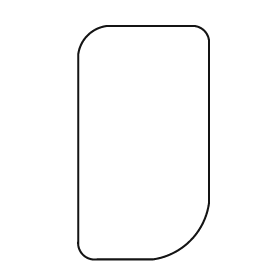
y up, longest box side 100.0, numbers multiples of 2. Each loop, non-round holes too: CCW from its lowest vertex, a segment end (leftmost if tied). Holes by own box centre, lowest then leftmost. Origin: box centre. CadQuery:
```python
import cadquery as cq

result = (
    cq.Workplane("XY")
    .moveTo(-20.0, -50.0)
    .lineTo(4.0, -50.0)
    .threePointArc((20.0, -42.0), (28.0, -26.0))
    .lineTo(28.0, 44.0)
    .threePointArc((26.0, 48.0), (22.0, 50.0))
    .lineTo(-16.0, 50.0)
    .threePointArc((-24.0, 46.0), (-28.0, 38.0))
    .lineTo(-28.0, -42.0)
    .threePointArc((-26.0, -48.0), (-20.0, -50.0))
    .close()
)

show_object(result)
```